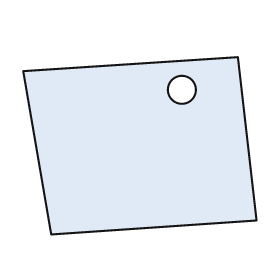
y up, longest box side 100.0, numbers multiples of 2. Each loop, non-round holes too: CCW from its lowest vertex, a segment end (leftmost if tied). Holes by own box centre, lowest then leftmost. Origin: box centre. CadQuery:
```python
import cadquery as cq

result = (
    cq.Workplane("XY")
    .moveTo(-38.0, -38.0)
    .lineTo(50.0, -32.0)
    .lineTo(42.0, 38.0)
    .lineTo(-50.0, 32.0)
    .close()
    .moveTo(18.0, 24.0)
    .circle(6.0)
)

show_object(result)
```